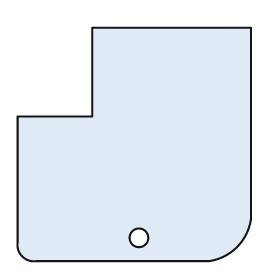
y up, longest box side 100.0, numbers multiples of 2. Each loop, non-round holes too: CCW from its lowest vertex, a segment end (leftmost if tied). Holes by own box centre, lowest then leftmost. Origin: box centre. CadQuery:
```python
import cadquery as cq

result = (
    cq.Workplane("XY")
    .moveTo(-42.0, -50.0)
    .lineTo(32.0, -50.0)
    .threePointArc((44.0, -44.0), (50.0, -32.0))
    .lineTo(50.0, 50.0)
    .lineTo(-18.0, 50.0)
    .lineTo(-18.0, 12.0)
    .lineTo(-50.0, 12.0)
    .lineTo(-50.0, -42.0)
    .threePointArc((-48.0, -48.0), (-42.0, -50.0))
    .close()
    .moveTo(2.0, -40.0)
    .circle(4.0)
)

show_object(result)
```